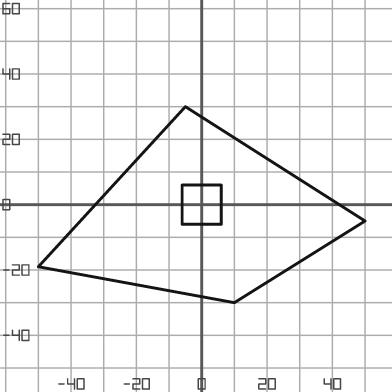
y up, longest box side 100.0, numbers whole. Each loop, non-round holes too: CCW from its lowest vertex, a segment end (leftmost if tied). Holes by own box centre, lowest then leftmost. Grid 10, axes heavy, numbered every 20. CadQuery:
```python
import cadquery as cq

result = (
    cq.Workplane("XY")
    .moveTo(10.0, -30.0)
    .lineTo(50.0, -5.0)
    .lineTo(-5.0, 30.0)
    .lineTo(-50.0, -19.0)
    .close()
    .moveTo(-6.0, -6.0)
    .lineTo(6.0, -6.0)
    .lineTo(6.0, 6.0)
    .lineTo(-6.0, 6.0)
    .close()
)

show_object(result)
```